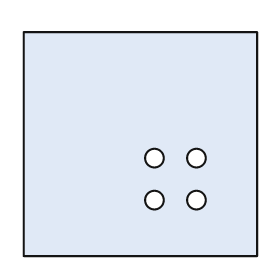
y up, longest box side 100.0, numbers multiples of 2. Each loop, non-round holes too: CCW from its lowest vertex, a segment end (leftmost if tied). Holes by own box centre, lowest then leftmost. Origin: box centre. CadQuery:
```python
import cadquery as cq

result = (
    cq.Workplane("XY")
    .moveTo(-50.0, -48.0)
    .lineTo(50.0, -48.0)
    .lineTo(50.0, 48.0)
    .lineTo(-50.0, 48.0)
    .close()
    .moveTo(6.0, -24.0)
    .circle(4.0)
    .moveTo(24.0, -24.0)
    .circle(4.0)
    .moveTo(6.0, -6.0)
    .circle(4.0)
    .moveTo(24.0, -6.0)
    .circle(4.0)
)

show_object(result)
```